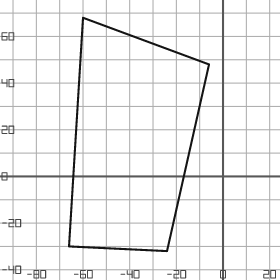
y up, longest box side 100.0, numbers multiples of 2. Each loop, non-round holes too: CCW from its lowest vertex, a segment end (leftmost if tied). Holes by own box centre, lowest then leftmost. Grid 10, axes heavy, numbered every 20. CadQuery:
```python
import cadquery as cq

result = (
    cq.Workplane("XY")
    .moveTo(-24.0, -32.0)
    .lineTo(-6.0, 48.0)
    .lineTo(-60.0, 68.0)
    .lineTo(-66.0, -30.0)
    .close()
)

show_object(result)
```